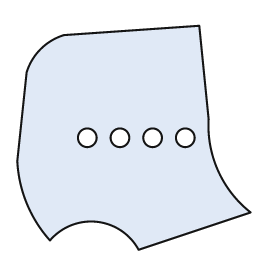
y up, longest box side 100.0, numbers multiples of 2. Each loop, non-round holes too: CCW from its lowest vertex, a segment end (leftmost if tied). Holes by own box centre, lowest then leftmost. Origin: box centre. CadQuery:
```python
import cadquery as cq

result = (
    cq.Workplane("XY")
    .moveTo(2.0, -48.0)
    .lineTo(50.0, -32.0)
    .threePointArc((36.0, -14.0), (32.0, 8.0))
    .lineTo(28.0, 48.0)
    .lineTo(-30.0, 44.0)
    .threePointArc((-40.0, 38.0), (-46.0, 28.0))
    .lineTo(-50.0, -10.0)
    .threePointArc((-46.0, -28.0), (-36.0, -44.0))
    .threePointArc((-16.0, -36.0), (2.0, -48.0))
    .close()
    .moveTo(-20.0, 0.0)
    .circle(4.0)
    .moveTo(-6.0, 0.0)
    .circle(4.0)
    .moveTo(8.0, 0.0)
    .circle(4.0)
    .moveTo(22.0, 0.0)
    .circle(4.0)
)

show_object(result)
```